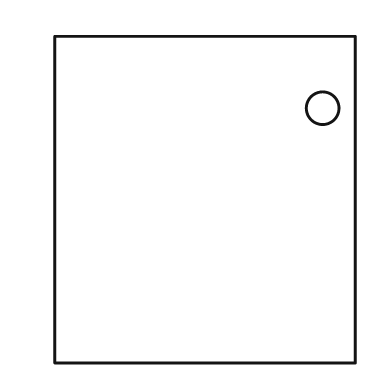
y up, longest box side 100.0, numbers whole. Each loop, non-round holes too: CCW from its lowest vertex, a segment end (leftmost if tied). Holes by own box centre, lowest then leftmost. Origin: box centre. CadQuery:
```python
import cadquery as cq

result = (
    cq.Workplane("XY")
    .moveTo(-46.0, -50.0)
    .lineTo(46.0, -50.0)
    .lineTo(46.0, 50.0)
    .lineTo(-46.0, 50.0)
    .close()
    .moveTo(36.0, 28.0)
    .circle(5.0)
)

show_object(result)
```